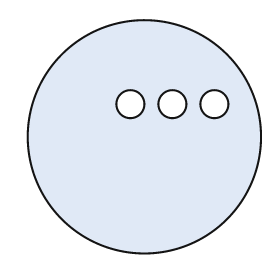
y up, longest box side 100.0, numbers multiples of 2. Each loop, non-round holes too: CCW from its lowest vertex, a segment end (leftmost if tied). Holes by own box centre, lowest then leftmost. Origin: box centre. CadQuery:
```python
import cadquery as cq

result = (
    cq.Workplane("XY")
    .moveTo(0.0, 0.0)
    .circle(50.0)
    .moveTo(-6.0, 14.0)
    .circle(6.0)
    .moveTo(12.0, 14.0)
    .circle(6.0)
    .moveTo(30.0, 14.0)
    .circle(6.0)
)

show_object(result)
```